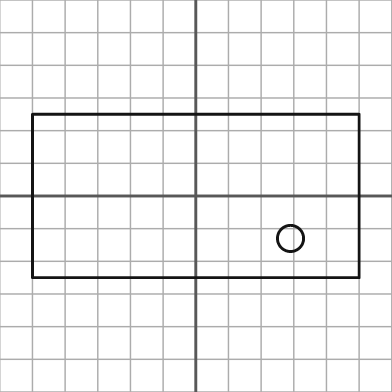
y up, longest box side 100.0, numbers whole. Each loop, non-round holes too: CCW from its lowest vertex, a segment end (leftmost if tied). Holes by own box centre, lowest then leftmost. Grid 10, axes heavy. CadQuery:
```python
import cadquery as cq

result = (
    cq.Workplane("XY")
    .moveTo(-50.0, -25.0)
    .lineTo(50.0, -25.0)
    .lineTo(50.0, 25.0)
    .lineTo(-50.0, 25.0)
    .close()
    .moveTo(29.0, -13.0)
    .circle(4.0)
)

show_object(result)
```